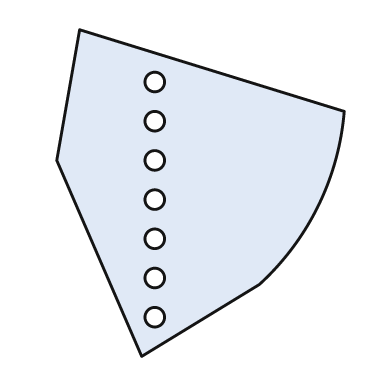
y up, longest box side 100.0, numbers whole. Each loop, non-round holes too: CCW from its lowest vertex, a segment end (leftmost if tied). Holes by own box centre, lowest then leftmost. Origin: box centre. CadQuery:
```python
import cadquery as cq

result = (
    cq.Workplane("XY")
    .moveTo(-18.0, -50.0)
    .lineTo(18.0, -28.0)
    .threePointArc((36.0, -4.0), (44.0, 25.0))
    .lineTo(-37.0, 50.0)
    .lineTo(-44.0, 10.0)
    .close()
    .moveTo(-14.0, -38.0)
    .circle(3.0)
    .moveTo(-14.0, -26.0)
    .circle(3.0)
    .moveTo(-14.0, -14.0)
    .circle(3.0)
    .moveTo(-14.0, -2.0)
    .circle(3.0)
    .moveTo(-14.0, 10.0)
    .circle(3.0)
    .moveTo(-14.0, 22.0)
    .circle(3.0)
    .moveTo(-14.0, 34.0)
    .circle(3.0)
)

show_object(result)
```